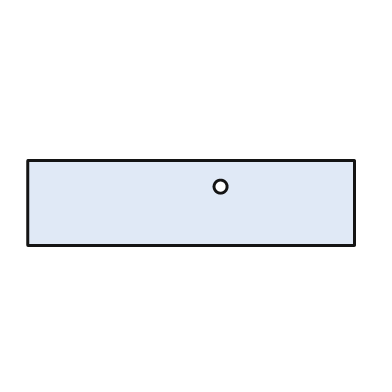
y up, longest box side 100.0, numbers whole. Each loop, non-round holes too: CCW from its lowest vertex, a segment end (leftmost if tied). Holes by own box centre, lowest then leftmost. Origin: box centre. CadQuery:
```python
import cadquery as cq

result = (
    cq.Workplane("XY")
    .moveTo(-50.0, -13.0)
    .lineTo(50.0, -13.0)
    .lineTo(50.0, 13.0)
    .lineTo(-50.0, 13.0)
    .close()
    .moveTo(9.0, 5.0)
    .circle(2.0)
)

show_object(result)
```